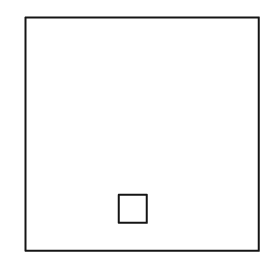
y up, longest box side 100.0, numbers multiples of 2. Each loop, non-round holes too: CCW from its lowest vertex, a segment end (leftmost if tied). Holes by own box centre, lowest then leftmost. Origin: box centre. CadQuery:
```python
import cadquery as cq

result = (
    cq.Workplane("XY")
    .moveTo(-50.0, -50.0)
    .lineTo(50.0, -50.0)
    .lineTo(50.0, 50.0)
    .lineTo(-50.0, 50.0)
    .close()
    .moveTo(-10.0, -38.0)
    .lineTo(2.0, -38.0)
    .lineTo(2.0, -26.0)
    .lineTo(-10.0, -26.0)
    .close()
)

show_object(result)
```